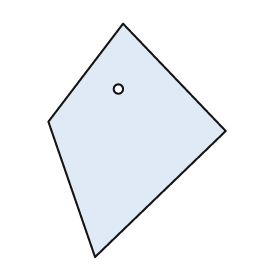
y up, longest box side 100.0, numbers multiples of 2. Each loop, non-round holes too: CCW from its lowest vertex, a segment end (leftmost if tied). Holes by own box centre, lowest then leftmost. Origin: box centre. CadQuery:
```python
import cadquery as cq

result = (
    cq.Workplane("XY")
    .moveTo(-18.0, -50.0)
    .lineTo(38.0, 4.0)
    .lineTo(-6.0, 50.0)
    .lineTo(-38.0, 8.0)
    .close()
    .moveTo(-8.0, 22.0)
    .circle(2.0)
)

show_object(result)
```